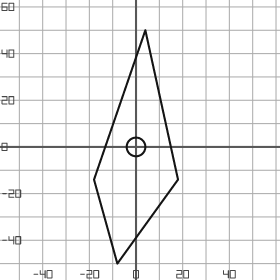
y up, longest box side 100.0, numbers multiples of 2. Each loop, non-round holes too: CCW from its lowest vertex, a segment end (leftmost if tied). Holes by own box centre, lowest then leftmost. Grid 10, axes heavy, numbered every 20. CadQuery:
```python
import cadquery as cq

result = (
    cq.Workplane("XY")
    .moveTo(-8.0, -50.0)
    .lineTo(18.0, -14.0)
    .lineTo(4.0, 50.0)
    .lineTo(-18.0, -14.0)
    .close()
    .moveTo(0.0, 0.0)
    .circle(4.0)
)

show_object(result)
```